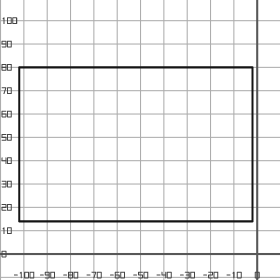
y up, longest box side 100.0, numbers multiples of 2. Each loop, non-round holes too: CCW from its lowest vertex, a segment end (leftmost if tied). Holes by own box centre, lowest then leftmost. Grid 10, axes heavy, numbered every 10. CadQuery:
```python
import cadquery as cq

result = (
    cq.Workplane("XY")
    .moveTo(-102.0, 14.0)
    .lineTo(-2.0, 14.0)
    .lineTo(-2.0, 80.0)
    .lineTo(-102.0, 80.0)
    .close()
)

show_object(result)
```